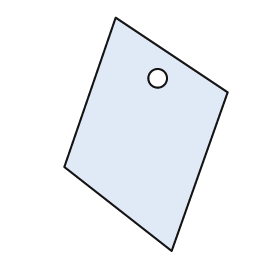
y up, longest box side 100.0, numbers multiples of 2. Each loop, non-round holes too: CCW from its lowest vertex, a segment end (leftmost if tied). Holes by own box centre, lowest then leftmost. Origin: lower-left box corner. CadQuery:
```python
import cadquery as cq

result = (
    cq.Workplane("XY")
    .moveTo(46.0, 0.0)
    .lineTo(70.0, 68.0)
    .lineTo(22.0, 100.0)
    .lineTo(0.0, 36.0)
    .close()
    .moveTo(40.0, 74.0)
    .circle(4.0)
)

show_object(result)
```